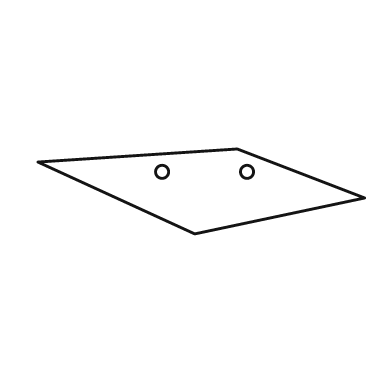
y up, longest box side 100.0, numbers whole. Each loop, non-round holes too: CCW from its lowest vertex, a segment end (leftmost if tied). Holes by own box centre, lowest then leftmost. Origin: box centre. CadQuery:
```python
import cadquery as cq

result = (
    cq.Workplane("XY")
    .moveTo(-2.0, -13.0)
    .lineTo(50.0, -2.0)
    .lineTo(11.0, 13.0)
    .lineTo(-50.0, 9.0)
    .close()
    .moveTo(-12.0, 6.0)
    .circle(2.0)
    .moveTo(14.0, 6.0)
    .circle(2.0)
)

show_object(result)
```